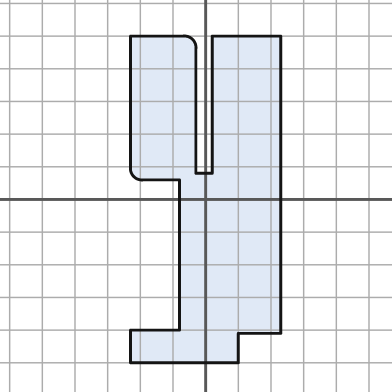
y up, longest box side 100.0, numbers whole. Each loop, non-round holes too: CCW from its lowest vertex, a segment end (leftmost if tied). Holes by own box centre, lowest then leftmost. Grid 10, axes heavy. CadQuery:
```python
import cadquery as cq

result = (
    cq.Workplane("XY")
    .moveTo(-23.0, -50.0)
    .lineTo(10.0, -50.0)
    .lineTo(10.0, -41.0)
    .lineTo(23.0, -41.0)
    .lineTo(23.0, 50.0)
    .lineTo(2.0, 50.0)
    .lineTo(2.0, 8.0)
    .lineTo(-3.0, 8.0)
    .lineTo(-3.0, 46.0)
    .threePointArc((-4.0, 49.0), (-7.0, 50.0))
    .lineTo(-23.0, 50.0)
    .lineTo(-23.0, 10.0)
    .threePointArc((-22.0, 7.0), (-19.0, 6.0))
    .lineTo(-8.0, 6.0)
    .lineTo(-8.0, -40.0)
    .lineTo(-23.0, -40.0)
    .close()
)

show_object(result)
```